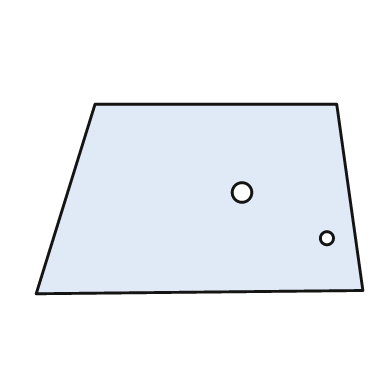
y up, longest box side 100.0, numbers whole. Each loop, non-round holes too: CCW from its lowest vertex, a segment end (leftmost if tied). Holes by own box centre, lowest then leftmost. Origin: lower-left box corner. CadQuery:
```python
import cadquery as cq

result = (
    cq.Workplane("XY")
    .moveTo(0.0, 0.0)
    .lineTo(100.0, 1.0)
    .lineTo(92.0, 58.0)
    .lineTo(18.0, 58.0)
    .close()
    .moveTo(89.0, 17.0)
    .circle(2.0)
    .moveTo(63.0, 31.0)
    .circle(3.0)
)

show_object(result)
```